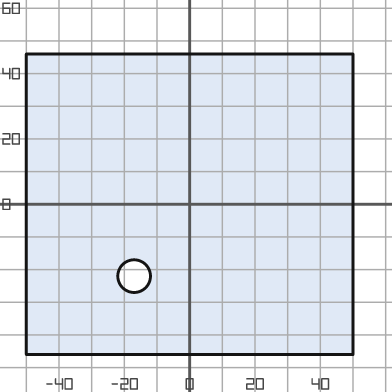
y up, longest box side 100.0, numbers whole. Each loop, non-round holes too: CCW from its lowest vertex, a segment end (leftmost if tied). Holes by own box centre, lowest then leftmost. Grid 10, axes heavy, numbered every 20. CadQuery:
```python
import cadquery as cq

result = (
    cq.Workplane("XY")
    .moveTo(-50.0, -46.0)
    .lineTo(50.0, -46.0)
    .lineTo(50.0, 46.0)
    .lineTo(-50.0, 46.0)
    .close()
    .moveTo(-17.0, -22.0)
    .circle(5.0)
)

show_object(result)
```